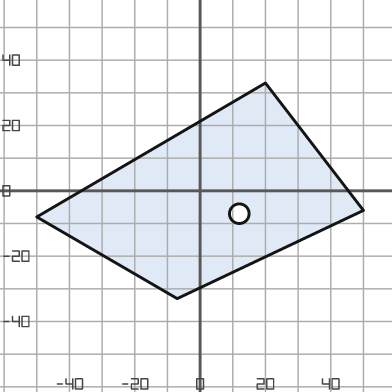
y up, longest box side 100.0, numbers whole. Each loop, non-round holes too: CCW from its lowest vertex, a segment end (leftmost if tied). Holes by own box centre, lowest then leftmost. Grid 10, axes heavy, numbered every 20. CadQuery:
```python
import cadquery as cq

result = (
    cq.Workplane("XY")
    .moveTo(-7.0, -33.0)
    .lineTo(50.0, -6.0)
    .lineTo(20.0, 33.0)
    .lineTo(-50.0, -8.0)
    .close()
    .moveTo(12.0, -7.0)
    .circle(3.0)
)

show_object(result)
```